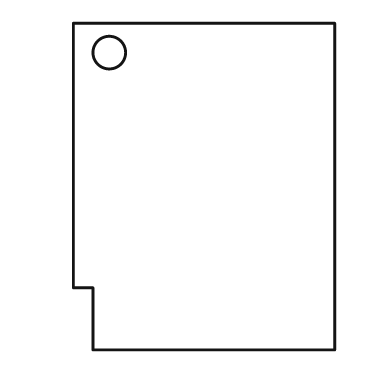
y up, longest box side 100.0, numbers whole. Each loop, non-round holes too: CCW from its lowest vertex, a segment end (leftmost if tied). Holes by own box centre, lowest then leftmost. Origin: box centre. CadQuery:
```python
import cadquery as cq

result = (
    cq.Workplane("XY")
    .moveTo(-34.0, -50.0)
    .lineTo(40.0, -50.0)
    .lineTo(40.0, 50.0)
    .lineTo(-40.0, 50.0)
    .lineTo(-40.0, -31.0)
    .lineTo(-34.0, -31.0)
    .close()
    .moveTo(-29.0, 41.0)
    .circle(5.0)
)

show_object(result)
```